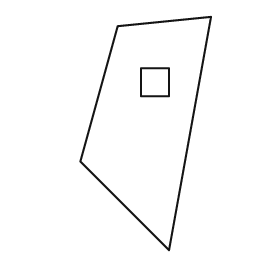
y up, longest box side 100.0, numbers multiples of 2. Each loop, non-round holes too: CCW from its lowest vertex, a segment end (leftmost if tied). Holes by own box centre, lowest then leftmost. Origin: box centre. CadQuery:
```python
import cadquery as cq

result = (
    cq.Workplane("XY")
    .moveTo(10.0, -50.0)
    .lineTo(28.0, 50.0)
    .lineTo(-12.0, 46.0)
    .lineTo(-28.0, -12.0)
    .close()
    .moveTo(-2.0, 16.0)
    .lineTo(10.0, 16.0)
    .lineTo(10.0, 28.0)
    .lineTo(-2.0, 28.0)
    .close()
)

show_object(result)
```